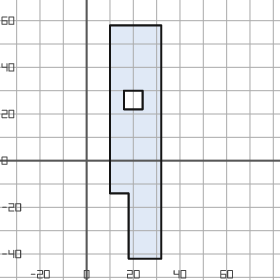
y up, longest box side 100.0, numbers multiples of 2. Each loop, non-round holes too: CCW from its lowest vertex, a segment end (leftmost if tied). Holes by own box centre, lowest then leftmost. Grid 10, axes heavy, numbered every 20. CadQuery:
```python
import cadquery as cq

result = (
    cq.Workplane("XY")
    .moveTo(18.0, -42.0)
    .lineTo(32.0, -42.0)
    .lineTo(32.0, 58.0)
    .lineTo(10.0, 58.0)
    .lineTo(10.0, -14.0)
    .lineTo(18.0, -14.0)
    .close()
    .moveTo(16.0, 22.0)
    .lineTo(24.0, 22.0)
    .lineTo(24.0, 30.0)
    .lineTo(16.0, 30.0)
    .close()
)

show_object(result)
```